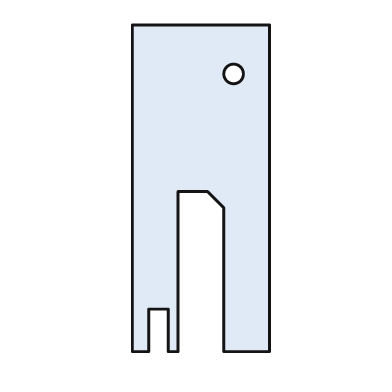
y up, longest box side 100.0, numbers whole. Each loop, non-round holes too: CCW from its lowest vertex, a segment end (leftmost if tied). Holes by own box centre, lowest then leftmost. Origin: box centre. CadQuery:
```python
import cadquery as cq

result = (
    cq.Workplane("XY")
    .moveTo(-21.0, -50.0)
    .lineTo(-16.0, -50.0)
    .lineTo(-16.0, -37.0)
    .lineTo(-10.0, -37.0)
    .lineTo(-10.0, -50.0)
    .lineTo(-7.0, -50.0)
    .lineTo(-7.0, -1.0)
    .lineTo(2.0, -1.0)
    .lineTo(7.0, -6.0)
    .lineTo(7.0, -50.0)
    .lineTo(21.0, -50.0)
    .lineTo(21.0, 50.0)
    .lineTo(-21.0, 50.0)
    .close()
    .moveTo(10.0, 35.0)
    .circle(3.0)
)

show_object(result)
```